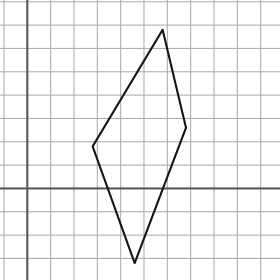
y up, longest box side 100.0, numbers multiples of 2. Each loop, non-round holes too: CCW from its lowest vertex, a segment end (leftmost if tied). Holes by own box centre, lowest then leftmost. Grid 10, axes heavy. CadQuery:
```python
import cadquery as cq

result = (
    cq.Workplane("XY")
    .moveTo(46.0, -32.0)
    .lineTo(68.0, 26.0)
    .lineTo(58.0, 68.0)
    .lineTo(28.0, 18.0)
    .close()
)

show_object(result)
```